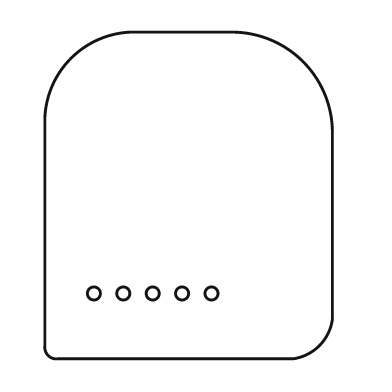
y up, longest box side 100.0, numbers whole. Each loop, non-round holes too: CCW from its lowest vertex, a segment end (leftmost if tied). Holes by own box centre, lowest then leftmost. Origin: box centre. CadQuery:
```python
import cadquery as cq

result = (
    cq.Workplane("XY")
    .moveTo(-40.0, -50.0)
    .lineTo(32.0, -50.0)
    .threePointArc((40.0, -46.0), (44.0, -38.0))
    .lineTo(44.0, 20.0)
    .threePointArc((35.0, 41.0), (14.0, 50.0))
    .lineTo(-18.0, 50.0)
    .threePointArc((-36.0, 42.0), (-44.0, 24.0))
    .lineTo(-44.0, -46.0)
    .threePointArc((-43.0, -49.0), (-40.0, -50.0))
    .close()
    .moveTo(-29.0, -30.0)
    .circle(2.0)
    .moveTo(-20.0, -30.0)
    .circle(2.0)
    .moveTo(-11.0, -30.0)
    .circle(2.0)
    .moveTo(-2.0, -30.0)
    .circle(2.0)
    .moveTo(7.0, -30.0)
    .circle(2.0)
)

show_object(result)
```